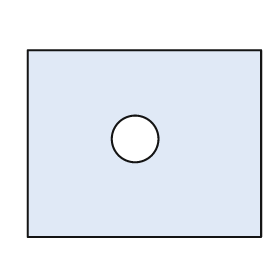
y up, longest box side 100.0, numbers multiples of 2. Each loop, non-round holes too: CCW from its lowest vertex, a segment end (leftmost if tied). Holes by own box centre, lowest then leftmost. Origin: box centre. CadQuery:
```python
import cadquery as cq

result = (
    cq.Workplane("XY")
    .moveTo(-50.0, -40.0)
    .lineTo(50.0, -40.0)
    .lineTo(50.0, 40.0)
    .lineTo(-50.0, 40.0)
    .close()
    .moveTo(-4.0, 2.0)
    .circle(10.0)
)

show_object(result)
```